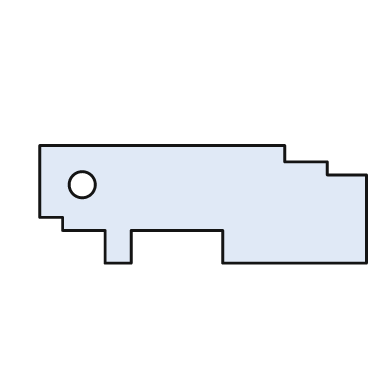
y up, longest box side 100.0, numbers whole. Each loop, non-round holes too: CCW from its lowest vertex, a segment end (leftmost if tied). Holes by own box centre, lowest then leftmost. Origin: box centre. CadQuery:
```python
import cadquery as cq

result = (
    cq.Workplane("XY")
    .moveTo(-30.0, -18.0)
    .lineTo(-22.0, -18.0)
    .lineTo(-22.0, -8.0)
    .lineTo(6.0, -8.0)
    .lineTo(6.0, -18.0)
    .lineTo(50.0, -18.0)
    .lineTo(50.0, 9.0)
    .lineTo(38.0, 9.0)
    .lineTo(38.0, 13.0)
    .lineTo(25.0, 13.0)
    .lineTo(25.0, 18.0)
    .lineTo(-50.0, 18.0)
    .lineTo(-50.0, -4.0)
    .lineTo(-43.0, -4.0)
    .lineTo(-43.0, -8.0)
    .lineTo(-30.0, -8.0)
    .close()
    .moveTo(-37.0, 6.0)
    .circle(4.0)
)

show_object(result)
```